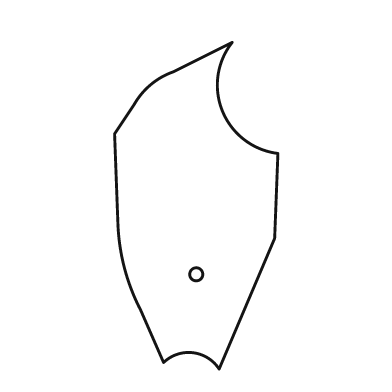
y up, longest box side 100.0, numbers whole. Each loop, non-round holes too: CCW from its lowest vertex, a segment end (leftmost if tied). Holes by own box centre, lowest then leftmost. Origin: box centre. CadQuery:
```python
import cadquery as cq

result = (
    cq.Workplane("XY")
    .moveTo(7.0, -50.0)
    .lineTo(24.0, -10.0)
    .lineTo(25.0, 16.0)
    .threePointArc((8.0, 29.0), (11.0, 50.0))
    .lineTo(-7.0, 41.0)
    .threePointArc((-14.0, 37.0), (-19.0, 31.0))
    .lineTo(-25.0, 22.0)
    .lineTo(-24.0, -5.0)
    .threePointArc((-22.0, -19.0), (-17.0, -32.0))
    .lineTo(-10.0, -48.0)
    .threePointArc((-1.0, -45.0), (7.0, -50.0))
    .close()
    .moveTo(0.0, -21.0)
    .circle(2.0)
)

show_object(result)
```